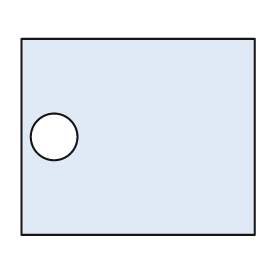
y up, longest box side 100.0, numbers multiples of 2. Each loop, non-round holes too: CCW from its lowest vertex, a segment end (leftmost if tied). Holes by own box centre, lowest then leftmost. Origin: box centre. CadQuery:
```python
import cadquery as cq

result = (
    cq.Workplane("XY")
    .moveTo(-50.0, -42.0)
    .lineTo(50.0, -42.0)
    .lineTo(50.0, 42.0)
    .lineTo(-50.0, 42.0)
    .close()
    .moveTo(-36.0, 0.0)
    .circle(10.0)
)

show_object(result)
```